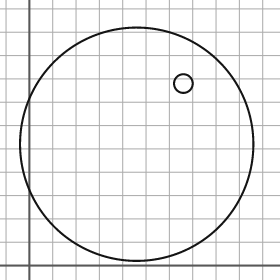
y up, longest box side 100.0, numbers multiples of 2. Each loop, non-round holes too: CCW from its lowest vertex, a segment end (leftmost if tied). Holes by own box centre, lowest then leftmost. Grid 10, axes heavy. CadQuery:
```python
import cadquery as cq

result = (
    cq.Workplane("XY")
    .moveTo(46.0, 52.0)
    .circle(50.0)
    .moveTo(66.0, 78.0)
    .circle(4.0)
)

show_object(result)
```